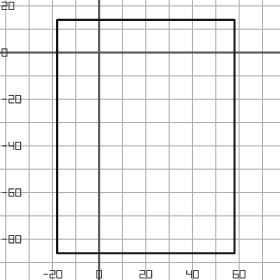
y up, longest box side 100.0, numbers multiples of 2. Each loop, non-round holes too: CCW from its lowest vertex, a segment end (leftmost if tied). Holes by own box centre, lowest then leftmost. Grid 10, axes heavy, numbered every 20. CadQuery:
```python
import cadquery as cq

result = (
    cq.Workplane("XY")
    .moveTo(-18.0, -86.0)
    .lineTo(58.0, -86.0)
    .lineTo(58.0, 14.0)
    .lineTo(-18.0, 14.0)
    .close()
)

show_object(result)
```